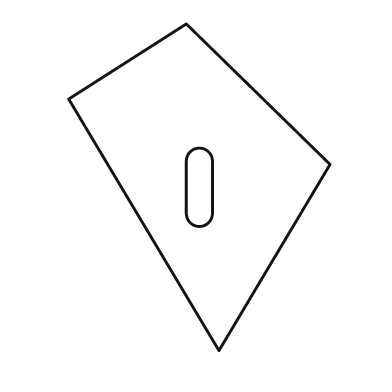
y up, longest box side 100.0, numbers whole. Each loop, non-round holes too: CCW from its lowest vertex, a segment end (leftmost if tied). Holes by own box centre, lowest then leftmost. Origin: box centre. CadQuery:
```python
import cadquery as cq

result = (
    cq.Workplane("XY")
    .moveTo(6.0, -50.0)
    .lineTo(40.0, 7.0)
    .lineTo(-4.0, 50.0)
    .lineTo(-40.0, 27.0)
    .close()
    .moveTo(-4.0, -8.0)
    .threePointArc((0.0, -12.0), (4.0, -8.0))
    .lineTo(4.0, 8.0)
    .threePointArc((0.0, 12.0), (-4.0, 8.0))
    .close()
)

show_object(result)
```